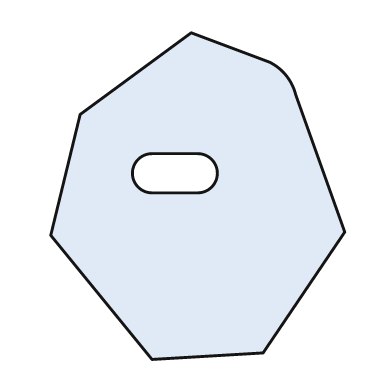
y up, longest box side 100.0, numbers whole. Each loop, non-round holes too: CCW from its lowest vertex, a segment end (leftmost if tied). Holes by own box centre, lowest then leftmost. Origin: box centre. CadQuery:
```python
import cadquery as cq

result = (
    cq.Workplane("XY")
    .moveTo(-14.0, -50.0)
    .lineTo(20.0, -48.0)
    .lineTo(45.0, -11.0)
    .lineTo(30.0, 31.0)
    .threePointArc((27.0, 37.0), (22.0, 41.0))
    .lineTo(-2.0, 50.0)
    .lineTo(-36.0, 25.0)
    .lineTo(-45.0, -12.0)
    .close()
    .moveTo(-14.0, 1.0)
    .lineTo(0.0, 1.0)
    .threePointArc((6.0, 7.0), (0.0, 13.0))
    .lineTo(-14.0, 13.0)
    .threePointArc((-20.0, 7.0), (-14.0, 1.0))
    .close()
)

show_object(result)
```